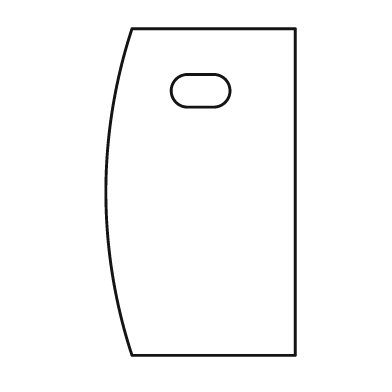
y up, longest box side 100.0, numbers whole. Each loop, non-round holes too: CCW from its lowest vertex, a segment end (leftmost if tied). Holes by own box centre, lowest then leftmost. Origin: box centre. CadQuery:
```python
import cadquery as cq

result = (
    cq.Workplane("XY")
    .moveTo(-21.0, -50.0)
    .lineTo(29.0, -50.0)
    .lineTo(29.0, 50.0)
    .lineTo(-21.0, 50.0)
    .threePointArc((-29.0, 0.0), (-21.0, -50.0))
    .close()
    .moveTo(-4.0, 26.0)
    .lineTo(4.0, 26.0)
    .threePointArc((9.0, 31.0), (4.0, 36.0))
    .lineTo(-4.0, 36.0)
    .threePointArc((-9.0, 31.0), (-4.0, 26.0))
    .close()
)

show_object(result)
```